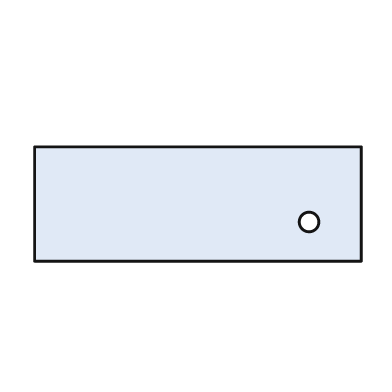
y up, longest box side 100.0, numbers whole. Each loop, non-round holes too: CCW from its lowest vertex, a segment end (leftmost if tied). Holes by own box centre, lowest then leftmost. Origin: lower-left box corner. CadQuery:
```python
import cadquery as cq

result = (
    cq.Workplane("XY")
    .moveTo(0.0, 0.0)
    .lineTo(100.0, 0.0)
    .lineTo(100.0, 35.0)
    .lineTo(0.0, 35.0)
    .close()
    .moveTo(84.0, 12.0)
    .circle(3.0)
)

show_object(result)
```